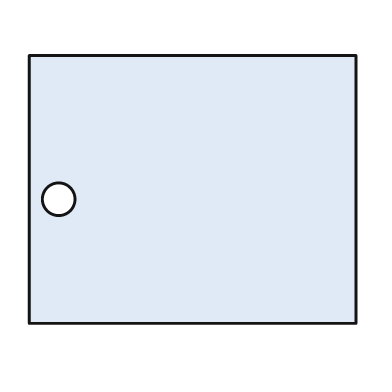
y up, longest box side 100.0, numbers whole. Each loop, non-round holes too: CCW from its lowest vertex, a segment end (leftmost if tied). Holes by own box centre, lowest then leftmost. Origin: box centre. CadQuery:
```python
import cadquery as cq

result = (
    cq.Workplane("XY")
    .moveTo(-50.0, -41.0)
    .lineTo(50.0, -41.0)
    .lineTo(50.0, 41.0)
    .lineTo(-50.0, 41.0)
    .close()
    .moveTo(-41.0, -3.0)
    .circle(5.0)
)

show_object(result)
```